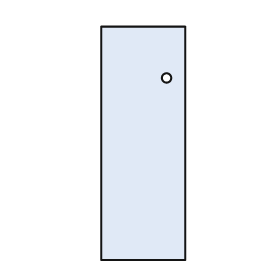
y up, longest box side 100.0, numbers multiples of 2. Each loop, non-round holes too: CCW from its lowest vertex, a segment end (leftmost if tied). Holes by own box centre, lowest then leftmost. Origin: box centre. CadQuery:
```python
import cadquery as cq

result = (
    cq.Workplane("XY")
    .moveTo(-18.0, -50.0)
    .lineTo(18.0, -50.0)
    .lineTo(18.0, 50.0)
    .lineTo(-18.0, 50.0)
    .close()
    .moveTo(10.0, 28.0)
    .circle(2.0)
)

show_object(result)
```